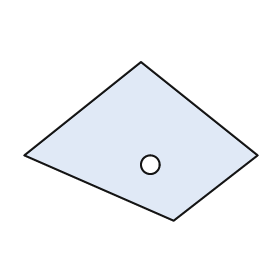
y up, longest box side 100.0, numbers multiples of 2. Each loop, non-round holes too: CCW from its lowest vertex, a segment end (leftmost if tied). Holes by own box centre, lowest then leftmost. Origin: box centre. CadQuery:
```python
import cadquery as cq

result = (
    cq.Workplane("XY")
    .moveTo(14.0, -34.0)
    .lineTo(50.0, -6.0)
    .lineTo(0.0, 34.0)
    .lineTo(-50.0, -6.0)
    .close()
    .moveTo(4.0, -10.0)
    .circle(4.0)
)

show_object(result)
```